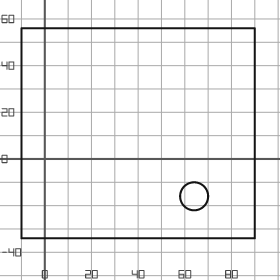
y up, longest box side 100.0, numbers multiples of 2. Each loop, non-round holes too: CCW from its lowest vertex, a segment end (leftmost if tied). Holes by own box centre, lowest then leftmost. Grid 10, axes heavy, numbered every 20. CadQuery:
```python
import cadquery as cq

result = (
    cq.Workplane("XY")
    .moveTo(-10.0, -34.0)
    .lineTo(90.0, -34.0)
    .lineTo(90.0, 56.0)
    .lineTo(-10.0, 56.0)
    .close()
    .moveTo(64.0, -16.0)
    .circle(6.0)
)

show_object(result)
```